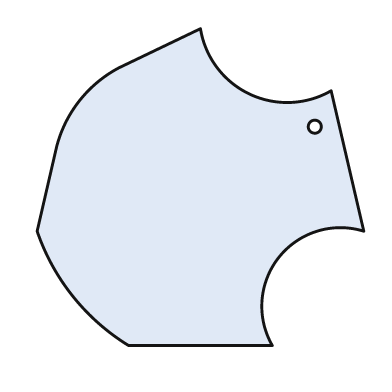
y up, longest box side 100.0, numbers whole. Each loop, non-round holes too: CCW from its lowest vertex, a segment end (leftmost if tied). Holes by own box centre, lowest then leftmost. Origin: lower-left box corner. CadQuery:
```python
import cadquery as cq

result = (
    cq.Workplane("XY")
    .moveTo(28.0, 0.0)
    .lineTo(72.0, 0.0)
    .threePointArc((74.0, 27.0), (100.0, 35.0))
    .lineTo(90.0, 78.0)
    .threePointArc((65.0, 77.0), (50.0, 97.0))
    .lineTo(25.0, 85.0)
    .threePointArc((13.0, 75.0), (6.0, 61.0))
    .lineTo(0.0, 35.0)
    .threePointArc((11.0, 15.0), (28.0, 0.0))
    .close()
    .moveTo(85.0, 67.0)
    .circle(2.0)
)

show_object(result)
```